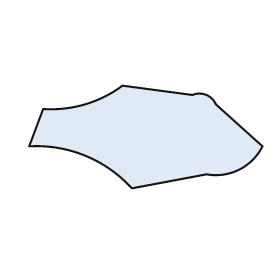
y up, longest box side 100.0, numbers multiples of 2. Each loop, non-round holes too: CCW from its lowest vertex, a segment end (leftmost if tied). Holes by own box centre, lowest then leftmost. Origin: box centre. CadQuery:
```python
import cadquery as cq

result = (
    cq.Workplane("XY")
    .moveTo(-6.0, -22.0)
    .lineTo(26.0, -16.0)
    .threePointArc((40.0, -14.0), (50.0, -4.0))
    .lineTo(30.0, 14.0)
    .threePointArc((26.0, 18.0), (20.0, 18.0))
    .lineTo(-10.0, 22.0)
    .threePointArc((-26.0, 14.0), (-44.0, 12.0))
    .lineTo(-50.0, -4.0)
    .threePointArc((-26.0, -8.0), (-6.0, -22.0))
    .close()
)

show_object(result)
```